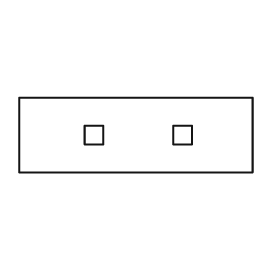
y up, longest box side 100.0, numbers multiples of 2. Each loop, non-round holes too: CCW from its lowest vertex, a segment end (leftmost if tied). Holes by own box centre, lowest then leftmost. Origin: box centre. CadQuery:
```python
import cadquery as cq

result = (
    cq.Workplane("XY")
    .moveTo(-50.0, -16.0)
    .lineTo(50.0, -16.0)
    .lineTo(50.0, 16.0)
    .lineTo(-50.0, 16.0)
    .close()
    .moveTo(-22.0, -4.0)
    .lineTo(-14.0, -4.0)
    .lineTo(-14.0, 4.0)
    .lineTo(-22.0, 4.0)
    .close()
    .moveTo(16.0, -4.0)
    .lineTo(24.0, -4.0)
    .lineTo(24.0, 4.0)
    .lineTo(16.0, 4.0)
    .close()
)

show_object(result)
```